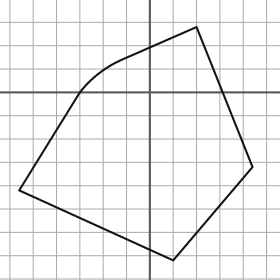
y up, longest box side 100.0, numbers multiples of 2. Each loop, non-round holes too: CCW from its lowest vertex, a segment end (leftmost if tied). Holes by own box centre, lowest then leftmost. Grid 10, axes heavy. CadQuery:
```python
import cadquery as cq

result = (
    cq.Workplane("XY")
    .moveTo(10.0, -72.0)
    .lineTo(44.0, -32.0)
    .lineTo(20.0, 28.0)
    .lineTo(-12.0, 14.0)
    .threePointArc((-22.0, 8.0), (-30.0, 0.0))
    .lineTo(-56.0, -42.0)
    .close()
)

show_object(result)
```